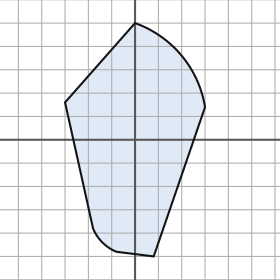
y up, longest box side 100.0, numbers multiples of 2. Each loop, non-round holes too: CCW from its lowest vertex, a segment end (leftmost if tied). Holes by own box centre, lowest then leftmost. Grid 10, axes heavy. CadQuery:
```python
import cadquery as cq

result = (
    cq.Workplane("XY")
    .moveTo(8.0, -50.0)
    .lineTo(30.0, 14.0)
    .threePointArc((20.0, 36.0), (0.0, 50.0))
    .lineTo(-30.0, 16.0)
    .lineTo(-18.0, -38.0)
    .threePointArc((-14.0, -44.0), (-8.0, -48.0))
    .close()
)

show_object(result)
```